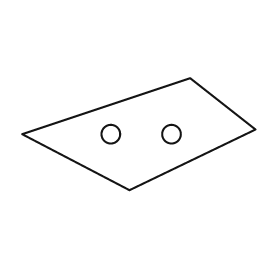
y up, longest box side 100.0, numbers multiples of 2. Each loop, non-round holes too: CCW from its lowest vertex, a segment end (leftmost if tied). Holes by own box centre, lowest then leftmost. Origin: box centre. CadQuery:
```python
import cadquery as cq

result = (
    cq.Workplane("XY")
    .moveTo(-4.0, -24.0)
    .lineTo(50.0, 2.0)
    .lineTo(22.0, 24.0)
    .lineTo(-50.0, 0.0)
    .close()
    .moveTo(-12.0, 0.0)
    .circle(4.0)
    .moveTo(14.0, 0.0)
    .circle(4.0)
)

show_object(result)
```